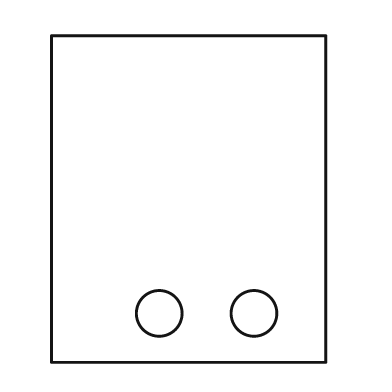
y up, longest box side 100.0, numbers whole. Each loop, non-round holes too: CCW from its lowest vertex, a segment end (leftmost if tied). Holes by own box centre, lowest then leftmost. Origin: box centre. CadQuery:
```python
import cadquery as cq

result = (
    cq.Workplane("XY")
    .moveTo(-42.0, -50.0)
    .lineTo(42.0, -50.0)
    .lineTo(42.0, 50.0)
    .lineTo(-42.0, 50.0)
    .close()
    .moveTo(-9.0, -35.0)
    .circle(7.0)
    .moveTo(20.0, -35.0)
    .circle(7.0)
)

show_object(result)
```